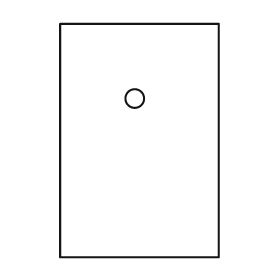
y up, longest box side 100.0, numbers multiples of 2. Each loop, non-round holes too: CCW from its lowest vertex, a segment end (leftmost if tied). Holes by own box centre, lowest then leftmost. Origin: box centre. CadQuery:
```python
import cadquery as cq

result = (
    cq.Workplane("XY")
    .moveTo(-34.0, -50.0)
    .lineTo(34.0, -50.0)
    .lineTo(34.0, 50.0)
    .lineTo(-34.0, 50.0)
    .close()
    .moveTo(-2.0, 18.0)
    .circle(4.0)
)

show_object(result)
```